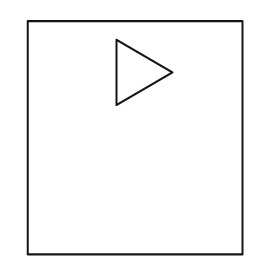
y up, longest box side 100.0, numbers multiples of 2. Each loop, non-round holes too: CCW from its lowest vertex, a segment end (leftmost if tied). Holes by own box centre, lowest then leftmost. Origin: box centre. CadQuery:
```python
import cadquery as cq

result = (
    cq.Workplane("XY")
    .moveTo(-46.0, -50.0)
    .lineTo(46.0, -50.0)
    .lineTo(46.0, 50.0)
    .lineTo(-46.0, 50.0)
    .close()
    .moveTo(-8.0, 14.0)
    .lineTo(16.0, 28.0)
    .lineTo(-8.0, 42.0)
    .close()
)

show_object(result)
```